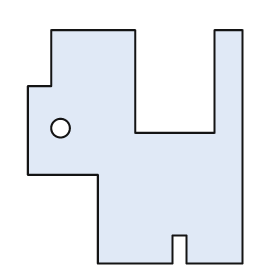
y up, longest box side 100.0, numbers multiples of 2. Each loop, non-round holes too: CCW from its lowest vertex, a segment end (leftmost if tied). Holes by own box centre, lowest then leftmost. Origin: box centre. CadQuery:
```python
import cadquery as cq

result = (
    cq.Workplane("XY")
    .moveTo(-16.0, -50.0)
    .lineTo(16.0, -50.0)
    .lineTo(16.0, -38.0)
    .lineTo(22.0, -38.0)
    .lineTo(22.0, -50.0)
    .lineTo(46.0, -50.0)
    .lineTo(46.0, 50.0)
    .lineTo(34.0, 50.0)
    .lineTo(34.0, 6.0)
    .lineTo(0.0, 6.0)
    .lineTo(0.0, 50.0)
    .lineTo(-36.0, 50.0)
    .lineTo(-36.0, 26.0)
    .lineTo(-46.0, 26.0)
    .lineTo(-46.0, -12.0)
    .lineTo(-16.0, -12.0)
    .close()
    .moveTo(-32.0, 8.0)
    .circle(4.0)
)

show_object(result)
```